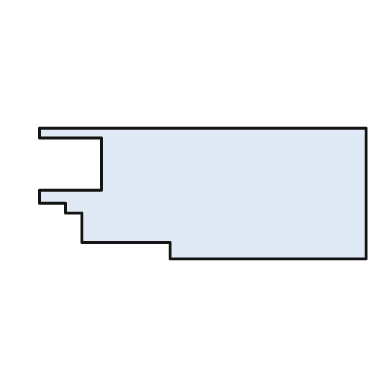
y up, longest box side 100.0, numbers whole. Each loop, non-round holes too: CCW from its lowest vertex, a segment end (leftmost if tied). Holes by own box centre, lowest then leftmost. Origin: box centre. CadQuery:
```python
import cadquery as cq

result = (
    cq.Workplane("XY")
    .moveTo(-10.0, -20.0)
    .lineTo(50.0, -20.0)
    .lineTo(50.0, 20.0)
    .lineTo(-50.0, 20.0)
    .lineTo(-50.0, 17.0)
    .lineTo(-31.0, 17.0)
    .lineTo(-31.0, 1.0)
    .lineTo(-50.0, 1.0)
    .lineTo(-50.0, -3.0)
    .lineTo(-42.0, -3.0)
    .lineTo(-42.0, -6.0)
    .lineTo(-37.0, -6.0)
    .lineTo(-37.0, -15.0)
    .lineTo(-10.0, -15.0)
    .close()
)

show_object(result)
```